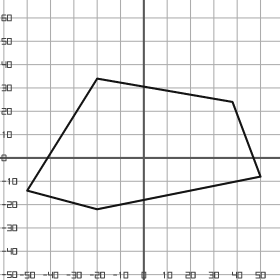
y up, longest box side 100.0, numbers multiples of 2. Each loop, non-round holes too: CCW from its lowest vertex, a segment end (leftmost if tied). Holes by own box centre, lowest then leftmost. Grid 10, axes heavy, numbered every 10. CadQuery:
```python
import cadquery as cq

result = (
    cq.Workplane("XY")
    .moveTo(-20.0, -22.0)
    .lineTo(50.0, -8.0)
    .lineTo(38.0, 24.0)
    .lineTo(-20.0, 34.0)
    .lineTo(-50.0, -14.0)
    .close()
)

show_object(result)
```